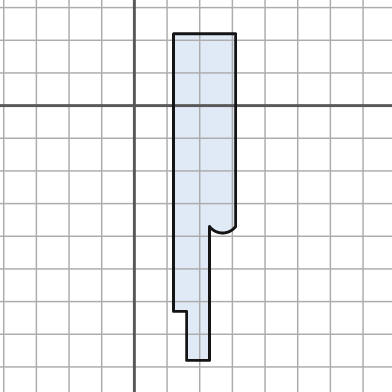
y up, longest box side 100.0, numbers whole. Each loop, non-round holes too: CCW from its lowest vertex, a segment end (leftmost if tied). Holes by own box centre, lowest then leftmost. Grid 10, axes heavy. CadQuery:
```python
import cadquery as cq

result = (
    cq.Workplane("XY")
    .moveTo(16.0, -78.0)
    .lineTo(23.0, -78.0)
    .lineTo(23.0, -37.0)
    .threePointArc((27.0, -39.0), (31.0, -37.0))
    .lineTo(31.0, 22.0)
    .lineTo(12.0, 22.0)
    .lineTo(12.0, -63.0)
    .lineTo(16.0, -63.0)
    .close()
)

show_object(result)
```